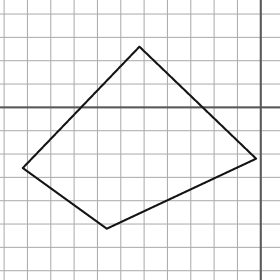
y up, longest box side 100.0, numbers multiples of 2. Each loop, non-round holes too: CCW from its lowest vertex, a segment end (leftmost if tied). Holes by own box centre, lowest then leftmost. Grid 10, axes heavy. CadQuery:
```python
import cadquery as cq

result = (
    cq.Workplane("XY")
    .moveTo(-66.0, -52.0)
    .lineTo(-2.0, -22.0)
    .lineTo(-52.0, 26.0)
    .lineTo(-102.0, -26.0)
    .close()
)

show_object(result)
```